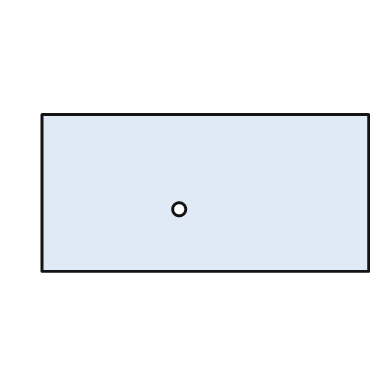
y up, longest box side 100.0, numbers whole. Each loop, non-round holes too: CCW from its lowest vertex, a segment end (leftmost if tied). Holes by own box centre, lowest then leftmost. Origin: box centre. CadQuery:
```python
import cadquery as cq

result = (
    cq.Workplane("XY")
    .moveTo(-50.0, -24.0)
    .lineTo(50.0, -24.0)
    .lineTo(50.0, 24.0)
    .lineTo(-50.0, 24.0)
    .close()
    .moveTo(-8.0, -5.0)
    .circle(2.0)
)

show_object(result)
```